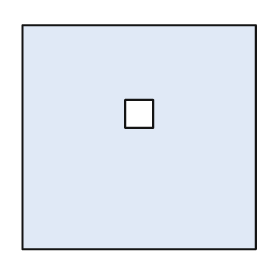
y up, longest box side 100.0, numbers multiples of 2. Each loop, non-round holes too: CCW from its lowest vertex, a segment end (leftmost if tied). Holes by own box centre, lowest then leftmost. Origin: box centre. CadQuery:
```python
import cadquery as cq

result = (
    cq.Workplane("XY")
    .moveTo(-50.0, -48.0)
    .lineTo(50.0, -48.0)
    .lineTo(50.0, 48.0)
    .lineTo(-50.0, 48.0)
    .close()
    .moveTo(-6.0, 4.0)
    .lineTo(6.0, 4.0)
    .lineTo(6.0, 16.0)
    .lineTo(-6.0, 16.0)
    .close()
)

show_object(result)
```